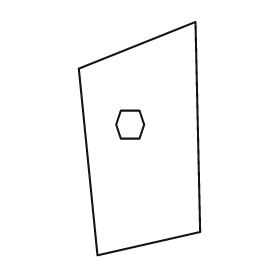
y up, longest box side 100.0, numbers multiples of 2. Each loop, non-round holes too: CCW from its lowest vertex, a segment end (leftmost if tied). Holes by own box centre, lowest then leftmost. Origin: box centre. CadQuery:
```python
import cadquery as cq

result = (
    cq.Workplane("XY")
    .moveTo(-18.0, -50.0)
    .lineTo(26.0, -40.0)
    .lineTo(24.0, 50.0)
    .lineTo(-26.0, 30.0)
    .close()
    .moveTo(-8.0, 0.0)
    .lineTo(0.0, 0.0)
    .lineTo(2.0, 6.0)
    .lineTo(0.0, 12.0)
    .lineTo(-8.0, 12.0)
    .lineTo(-10.0, 6.0)
    .close()
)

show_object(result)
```